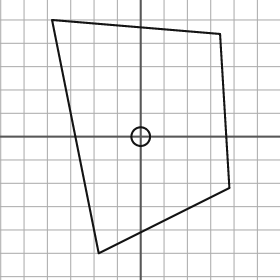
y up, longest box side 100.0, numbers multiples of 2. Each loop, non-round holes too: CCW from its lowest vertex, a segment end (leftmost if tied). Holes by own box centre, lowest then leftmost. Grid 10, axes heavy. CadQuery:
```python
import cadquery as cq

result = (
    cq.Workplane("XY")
    .moveTo(-18.0, -50.0)
    .lineTo(38.0, -22.0)
    .lineTo(34.0, 44.0)
    .lineTo(-38.0, 50.0)
    .close()
    .moveTo(0.0, 0.0)
    .circle(4.0)
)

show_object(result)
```